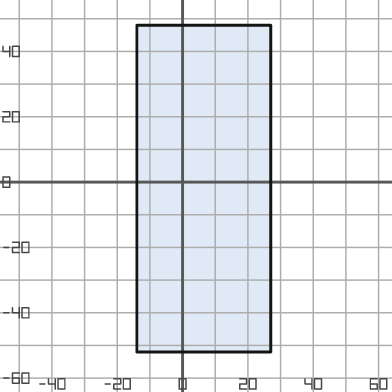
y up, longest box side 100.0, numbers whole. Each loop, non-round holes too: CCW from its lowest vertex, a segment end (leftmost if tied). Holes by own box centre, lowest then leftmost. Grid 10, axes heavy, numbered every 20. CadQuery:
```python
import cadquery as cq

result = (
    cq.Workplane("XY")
    .moveTo(-14.0, -52.0)
    .lineTo(27.0, -52.0)
    .lineTo(27.0, 48.0)
    .lineTo(-14.0, 48.0)
    .close()
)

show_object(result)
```